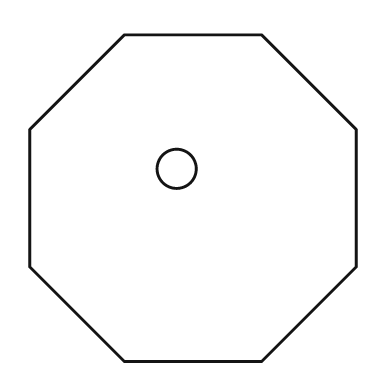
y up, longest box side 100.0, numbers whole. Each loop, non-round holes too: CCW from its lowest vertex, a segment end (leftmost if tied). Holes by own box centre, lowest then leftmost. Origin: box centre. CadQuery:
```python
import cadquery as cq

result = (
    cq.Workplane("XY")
    .moveTo(-21.0, -50.0)
    .lineTo(21.0, -50.0)
    .lineTo(50.0, -21.0)
    .lineTo(50.0, 21.0)
    .lineTo(21.0, 50.0)
    .lineTo(-21.0, 50.0)
    .lineTo(-50.0, 21.0)
    .lineTo(-50.0, -21.0)
    .close()
    .moveTo(-5.0, 9.0)
    .circle(6.0)
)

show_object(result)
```